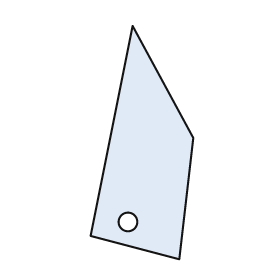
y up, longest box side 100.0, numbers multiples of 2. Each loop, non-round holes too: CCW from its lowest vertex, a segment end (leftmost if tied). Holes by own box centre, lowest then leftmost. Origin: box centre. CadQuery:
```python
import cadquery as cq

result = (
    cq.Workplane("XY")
    .moveTo(16.0, -50.0)
    .lineTo(22.0, 2.0)
    .lineTo(-4.0, 50.0)
    .lineTo(-22.0, -40.0)
    .close()
    .moveTo(-6.0, -34.0)
    .circle(4.0)
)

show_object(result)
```